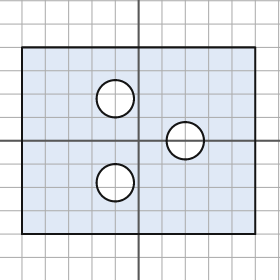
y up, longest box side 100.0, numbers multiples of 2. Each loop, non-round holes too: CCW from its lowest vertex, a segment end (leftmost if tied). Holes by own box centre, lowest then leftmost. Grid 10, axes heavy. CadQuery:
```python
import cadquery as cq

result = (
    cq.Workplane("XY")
    .moveTo(-50.0, -40.0)
    .lineTo(50.0, -40.0)
    .lineTo(50.0, 40.0)
    .lineTo(-50.0, 40.0)
    .close()
    .moveTo(-10.0, -18.0)
    .circle(8.0)
    .moveTo(20.0, 0.0)
    .circle(8.0)
    .moveTo(-10.0, 18.0)
    .circle(8.0)
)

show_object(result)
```